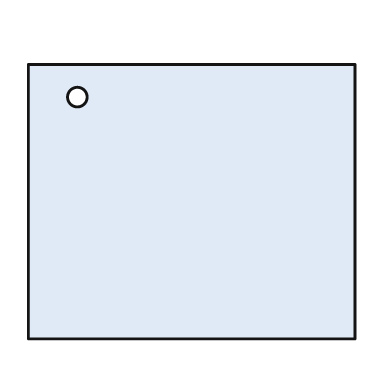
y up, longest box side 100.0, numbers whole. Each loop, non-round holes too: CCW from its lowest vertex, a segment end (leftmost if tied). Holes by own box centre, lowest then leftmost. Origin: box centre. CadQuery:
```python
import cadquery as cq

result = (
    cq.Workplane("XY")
    .moveTo(-50.0, -42.0)
    .lineTo(50.0, -42.0)
    .lineTo(50.0, 42.0)
    .lineTo(-50.0, 42.0)
    .close()
    .moveTo(-35.0, 32.0)
    .circle(3.0)
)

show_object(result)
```